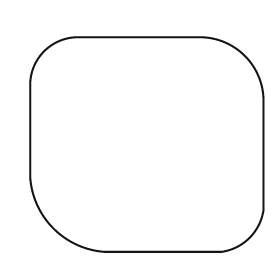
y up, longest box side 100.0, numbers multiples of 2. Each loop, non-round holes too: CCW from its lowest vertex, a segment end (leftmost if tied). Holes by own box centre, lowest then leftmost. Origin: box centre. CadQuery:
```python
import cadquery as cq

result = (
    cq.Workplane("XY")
    .moveTo(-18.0, -46.0)
    .lineTo(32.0, -46.0)
    .threePointArc((44.0, -40.0), (50.0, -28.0))
    .lineTo(50.0, 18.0)
    .threePointArc((42.0, 38.0), (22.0, 46.0))
    .lineTo(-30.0, 46.0)
    .threePointArc((-44.0, 40.0), (-50.0, 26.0))
    .lineTo(-50.0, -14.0)
    .threePointArc((-40.0, -36.0), (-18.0, -46.0))
    .close()
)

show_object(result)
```